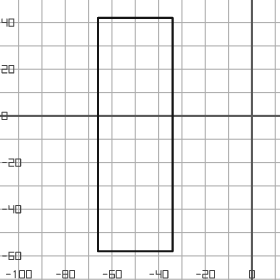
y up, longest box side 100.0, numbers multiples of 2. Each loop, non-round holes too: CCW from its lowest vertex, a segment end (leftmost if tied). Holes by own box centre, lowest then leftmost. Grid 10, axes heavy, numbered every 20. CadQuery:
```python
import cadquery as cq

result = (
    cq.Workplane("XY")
    .moveTo(-66.0, -58.0)
    .lineTo(-34.0, -58.0)
    .lineTo(-34.0, 42.0)
    .lineTo(-66.0, 42.0)
    .close()
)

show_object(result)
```